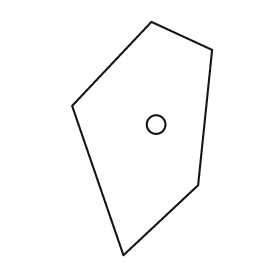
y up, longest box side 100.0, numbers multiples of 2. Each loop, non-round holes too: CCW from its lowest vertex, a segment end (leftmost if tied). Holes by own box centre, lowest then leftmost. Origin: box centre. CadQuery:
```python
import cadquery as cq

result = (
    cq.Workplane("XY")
    .moveTo(-8.0, -50.0)
    .lineTo(24.0, -20.0)
    .lineTo(30.0, 38.0)
    .lineTo(4.0, 50.0)
    .lineTo(-30.0, 14.0)
    .close()
    .moveTo(6.0, 6.0)
    .circle(4.0)
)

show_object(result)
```